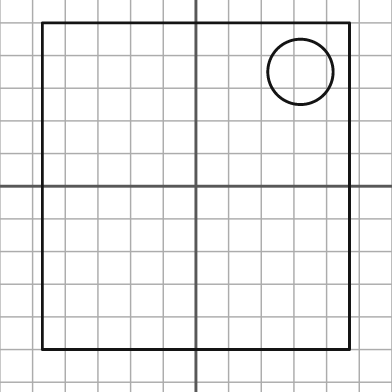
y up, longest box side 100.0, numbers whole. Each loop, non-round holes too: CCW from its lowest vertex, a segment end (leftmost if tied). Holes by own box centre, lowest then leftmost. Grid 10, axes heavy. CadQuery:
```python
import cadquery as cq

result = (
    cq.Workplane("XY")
    .moveTo(-47.0, -50.0)
    .lineTo(47.0, -50.0)
    .lineTo(47.0, 50.0)
    .lineTo(-47.0, 50.0)
    .close()
    .moveTo(32.0, 35.0)
    .circle(10.0)
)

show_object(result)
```